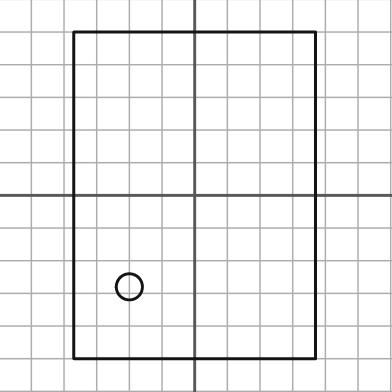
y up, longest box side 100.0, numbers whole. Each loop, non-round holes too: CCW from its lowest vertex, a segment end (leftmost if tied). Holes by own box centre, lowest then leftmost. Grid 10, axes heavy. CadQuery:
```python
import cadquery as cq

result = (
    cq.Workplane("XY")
    .moveTo(-37.0, -50.0)
    .lineTo(37.0, -50.0)
    .lineTo(37.0, 50.0)
    .lineTo(-37.0, 50.0)
    .close()
    .moveTo(-20.0, -28.0)
    .circle(4.0)
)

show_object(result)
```